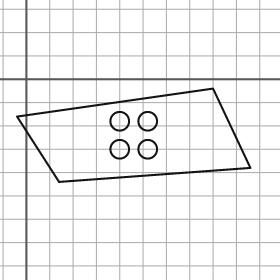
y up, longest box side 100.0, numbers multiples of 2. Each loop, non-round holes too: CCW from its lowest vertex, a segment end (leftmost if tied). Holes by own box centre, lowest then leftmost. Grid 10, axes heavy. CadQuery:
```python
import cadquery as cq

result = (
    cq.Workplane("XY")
    .moveTo(14.0, -44.0)
    .lineTo(96.0, -38.0)
    .lineTo(80.0, -4.0)
    .lineTo(-4.0, -16.0)
    .close()
    .moveTo(40.0, -30.0)
    .circle(4.0)
    .moveTo(52.0, -30.0)
    .circle(4.0)
    .moveTo(40.0, -18.0)
    .circle(4.0)
    .moveTo(52.0, -18.0)
    .circle(4.0)
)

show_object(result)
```